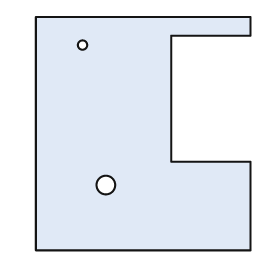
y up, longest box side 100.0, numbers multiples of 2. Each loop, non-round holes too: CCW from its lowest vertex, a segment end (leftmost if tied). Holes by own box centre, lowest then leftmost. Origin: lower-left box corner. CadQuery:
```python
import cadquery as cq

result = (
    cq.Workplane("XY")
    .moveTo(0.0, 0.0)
    .lineTo(92.0, 0.0)
    .lineTo(92.0, 38.0)
    .lineTo(58.0, 38.0)
    .lineTo(58.0, 92.0)
    .lineTo(92.0, 92.0)
    .lineTo(92.0, 100.0)
    .lineTo(0.0, 100.0)
    .close()
    .moveTo(30.0, 28.0)
    .circle(4.0)
    .moveTo(20.0, 88.0)
    .circle(2.0)
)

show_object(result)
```